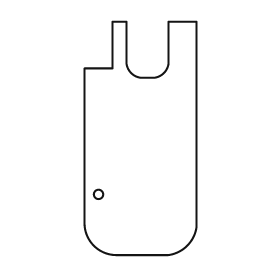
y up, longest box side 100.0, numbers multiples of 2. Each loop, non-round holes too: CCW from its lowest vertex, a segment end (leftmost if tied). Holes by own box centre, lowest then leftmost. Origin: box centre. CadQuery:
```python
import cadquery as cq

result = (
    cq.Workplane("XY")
    .moveTo(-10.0, -50.0)
    .lineTo(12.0, -50.0)
    .threePointArc((20.0, -46.0), (24.0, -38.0))
    .lineTo(24.0, 50.0)
    .lineTo(12.0, 50.0)
    .lineTo(12.0, 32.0)
    .threePointArc((10.0, 28.0), (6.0, 26.0))
    .lineTo(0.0, 26.0)
    .threePointArc((-4.0, 28.0), (-6.0, 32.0))
    .lineTo(-6.0, 50.0)
    .lineTo(-12.0, 50.0)
    .lineTo(-12.0, 30.0)
    .lineTo(-24.0, 30.0)
    .lineTo(-24.0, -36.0)
    .threePointArc((-20.0, -46.0), (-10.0, -50.0))
    .close()
    .moveTo(-18.0, -24.0)
    .circle(2.0)
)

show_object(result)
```